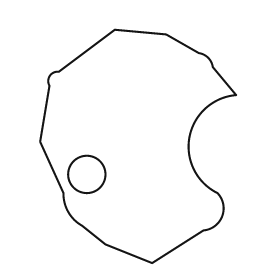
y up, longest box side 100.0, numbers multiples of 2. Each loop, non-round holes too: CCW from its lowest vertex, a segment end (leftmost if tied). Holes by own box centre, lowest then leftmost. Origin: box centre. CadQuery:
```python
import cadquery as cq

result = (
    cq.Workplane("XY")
    .moveTo(6.0, -50.0)
    .lineTo(28.0, -36.0)
    .threePointArc((36.0, -30.0), (34.0, -20.0))
    .threePointArc((22.0, 4.0), (42.0, 22.0))
    .lineTo(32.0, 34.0)
    .threePointArc((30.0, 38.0), (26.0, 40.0))
    .lineTo(12.0, 48.0)
    .lineTo(-10.0, 50.0)
    .lineTo(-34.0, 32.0)
    .threePointArc((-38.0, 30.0), (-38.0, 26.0))
    .lineTo(-42.0, 2.0)
    .lineTo(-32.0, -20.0)
    .threePointArc((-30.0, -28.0), (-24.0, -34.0))
    .lineTo(-14.0, -42.0)
    .close()
    .moveTo(-22.0, -12.0)
    .circle(8.0)
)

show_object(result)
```